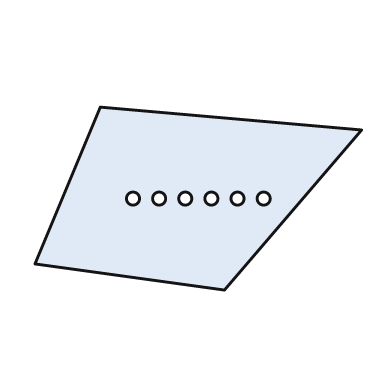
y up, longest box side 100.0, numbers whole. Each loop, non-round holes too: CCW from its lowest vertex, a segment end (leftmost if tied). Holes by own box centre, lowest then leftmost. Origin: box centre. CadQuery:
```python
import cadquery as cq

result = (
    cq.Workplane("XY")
    .moveTo(8.0, -28.0)
    .lineTo(50.0, 21.0)
    .lineTo(-30.0, 28.0)
    .lineTo(-50.0, -20.0)
    .close()
    .moveTo(-20.0, 0.0)
    .circle(2.0)
    .moveTo(-12.0, 0.0)
    .circle(2.0)
    .moveTo(-4.0, 0.0)
    .circle(2.0)
    .moveTo(4.0, 0.0)
    .circle(2.0)
    .moveTo(12.0, 0.0)
    .circle(2.0)
    .moveTo(20.0, 0.0)
    .circle(2.0)
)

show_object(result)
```